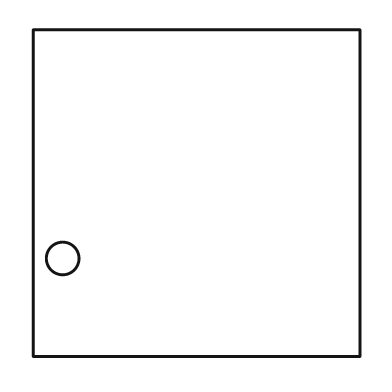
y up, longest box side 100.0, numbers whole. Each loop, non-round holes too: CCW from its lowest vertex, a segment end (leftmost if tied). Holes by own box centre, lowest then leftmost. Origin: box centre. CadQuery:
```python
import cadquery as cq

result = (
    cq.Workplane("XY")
    .moveTo(-50.0, -50.0)
    .lineTo(50.0, -50.0)
    .lineTo(50.0, 50.0)
    .lineTo(-50.0, 50.0)
    .close()
    .moveTo(-41.0, -20.0)
    .circle(5.0)
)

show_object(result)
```